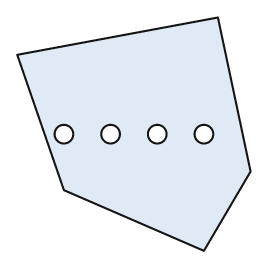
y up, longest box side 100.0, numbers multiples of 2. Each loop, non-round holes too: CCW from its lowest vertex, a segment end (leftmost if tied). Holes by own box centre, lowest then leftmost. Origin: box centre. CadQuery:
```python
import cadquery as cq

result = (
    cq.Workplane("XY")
    .moveTo(30.0, -50.0)
    .lineTo(50.0, -16.0)
    .lineTo(36.0, 50.0)
    .lineTo(-50.0, 34.0)
    .lineTo(-30.0, -24.0)
    .close()
    .moveTo(-30.0, 0.0)
    .circle(4.0)
    .moveTo(-10.0, 0.0)
    .circle(4.0)
    .moveTo(10.0, 0.0)
    .circle(4.0)
    .moveTo(30.0, 0.0)
    .circle(4.0)
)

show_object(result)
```